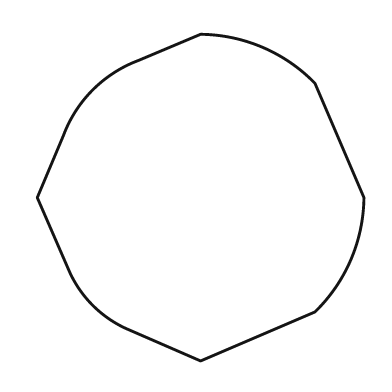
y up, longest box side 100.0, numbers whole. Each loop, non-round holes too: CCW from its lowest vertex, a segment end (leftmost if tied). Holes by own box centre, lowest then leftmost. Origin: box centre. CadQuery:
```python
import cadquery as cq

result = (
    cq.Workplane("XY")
    .moveTo(0.0, -50.0)
    .lineTo(35.0, -35.0)
    .threePointArc((46.0, -19.0), (50.0, 0.0))
    .lineTo(35.0, 35.0)
    .threePointArc((19.0, 46.0), (0.0, 50.0))
    .lineTo(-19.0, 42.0)
    .threePointArc((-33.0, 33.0), (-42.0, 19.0))
    .lineTo(-50.0, 0.0)
    .lineTo(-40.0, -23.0)
    .threePointArc((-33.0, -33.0), (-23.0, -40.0))
    .close()
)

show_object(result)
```